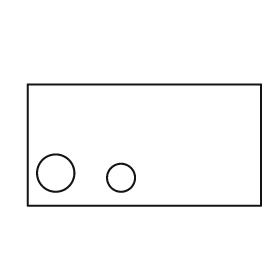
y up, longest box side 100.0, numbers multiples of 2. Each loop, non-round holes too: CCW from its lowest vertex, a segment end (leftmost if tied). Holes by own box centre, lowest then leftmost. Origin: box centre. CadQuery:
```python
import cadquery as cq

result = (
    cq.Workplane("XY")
    .moveTo(-50.0, -26.0)
    .lineTo(50.0, -26.0)
    .lineTo(50.0, 26.0)
    .lineTo(-50.0, 26.0)
    .close()
    .moveTo(-10.0, -14.0)
    .circle(6.0)
    .moveTo(-38.0, -12.0)
    .circle(8.0)
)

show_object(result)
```